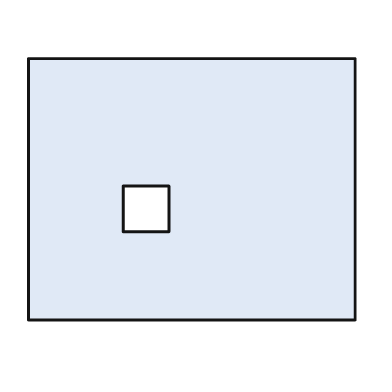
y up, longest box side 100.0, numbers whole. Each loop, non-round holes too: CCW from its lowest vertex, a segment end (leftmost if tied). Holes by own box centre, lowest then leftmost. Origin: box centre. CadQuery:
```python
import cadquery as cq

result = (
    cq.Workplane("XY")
    .moveTo(-50.0, -40.0)
    .lineTo(50.0, -40.0)
    .lineTo(50.0, 40.0)
    .lineTo(-50.0, 40.0)
    .close()
    .moveTo(-21.0, -13.0)
    .lineTo(-7.0, -13.0)
    .lineTo(-7.0, 1.0)
    .lineTo(-21.0, 1.0)
    .close()
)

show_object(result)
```